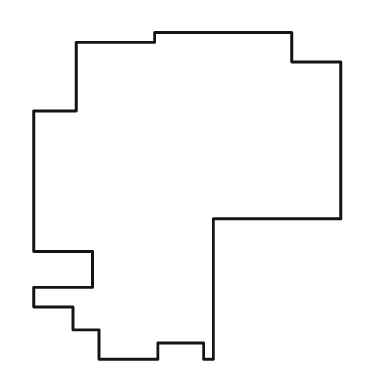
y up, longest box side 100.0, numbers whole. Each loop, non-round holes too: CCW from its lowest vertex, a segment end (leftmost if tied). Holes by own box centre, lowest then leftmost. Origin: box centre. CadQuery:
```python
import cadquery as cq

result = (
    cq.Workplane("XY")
    .moveTo(-27.0, -50.0)
    .lineTo(-9.0, -50.0)
    .lineTo(-9.0, -45.0)
    .lineTo(5.0, -45.0)
    .lineTo(5.0, -50.0)
    .lineTo(8.0, -50.0)
    .lineTo(8.0, -7.0)
    .lineTo(47.0, -7.0)
    .lineTo(47.0, 41.0)
    .lineTo(32.0, 41.0)
    .lineTo(32.0, 50.0)
    .lineTo(-10.0, 50.0)
    .lineTo(-10.0, 47.0)
    .lineTo(-34.0, 47.0)
    .lineTo(-34.0, 26.0)
    .lineTo(-47.0, 26.0)
    .lineTo(-47.0, -17.0)
    .lineTo(-29.0, -17.0)
    .lineTo(-29.0, -28.0)
    .lineTo(-47.0, -28.0)
    .lineTo(-47.0, -34.0)
    .lineTo(-35.0, -34.0)
    .lineTo(-35.0, -41.0)
    .lineTo(-27.0, -41.0)
    .close()
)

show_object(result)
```